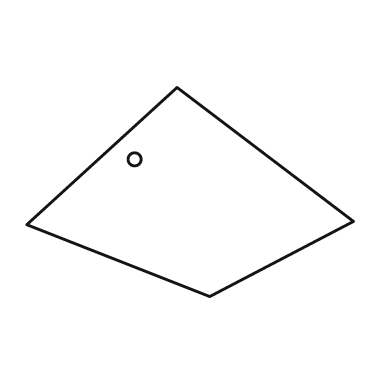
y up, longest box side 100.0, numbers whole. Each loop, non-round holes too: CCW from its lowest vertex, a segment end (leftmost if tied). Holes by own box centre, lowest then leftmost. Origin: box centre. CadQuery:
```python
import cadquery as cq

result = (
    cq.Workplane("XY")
    .moveTo(6.0, -32.0)
    .lineTo(50.0, -9.0)
    .lineTo(-4.0, 32.0)
    .lineTo(-50.0, -10.0)
    .close()
    .moveTo(-17.0, 10.0)
    .circle(2.0)
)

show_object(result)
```